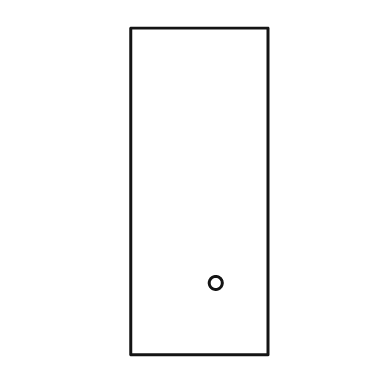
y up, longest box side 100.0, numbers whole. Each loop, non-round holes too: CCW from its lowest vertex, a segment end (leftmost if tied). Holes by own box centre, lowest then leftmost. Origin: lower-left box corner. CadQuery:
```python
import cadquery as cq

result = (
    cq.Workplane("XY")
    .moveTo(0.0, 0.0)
    .lineTo(42.0, 0.0)
    .lineTo(42.0, 100.0)
    .lineTo(0.0, 100.0)
    .close()
    .moveTo(26.0, 22.0)
    .circle(2.0)
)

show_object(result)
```